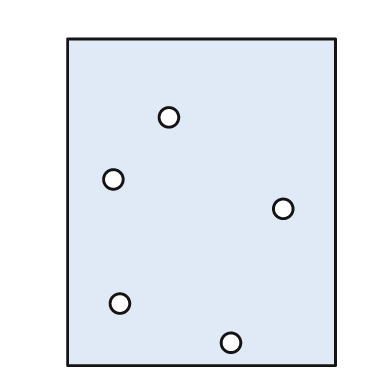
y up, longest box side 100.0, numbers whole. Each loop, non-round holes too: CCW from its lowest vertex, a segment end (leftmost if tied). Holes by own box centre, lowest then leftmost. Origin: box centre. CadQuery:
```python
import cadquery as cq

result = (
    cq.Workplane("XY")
    .moveTo(-41.0, -50.0)
    .lineTo(41.0, -50.0)
    .lineTo(41.0, 50.0)
    .lineTo(-41.0, 50.0)
    .close()
    .moveTo(9.0, -43.0)
    .circle(3.0)
    .moveTo(-25.0, -31.0)
    .circle(3.0)
    .moveTo(25.0, -2.0)
    .circle(3.0)
    .moveTo(-27.0, 7.0)
    .circle(3.0)
    .moveTo(-10.0, 26.0)
    .circle(3.0)
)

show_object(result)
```